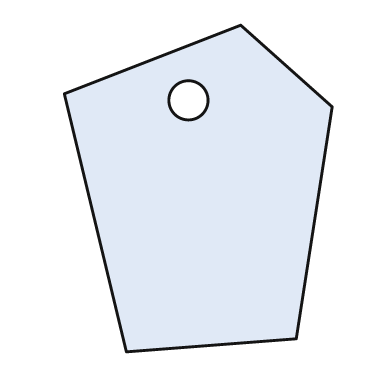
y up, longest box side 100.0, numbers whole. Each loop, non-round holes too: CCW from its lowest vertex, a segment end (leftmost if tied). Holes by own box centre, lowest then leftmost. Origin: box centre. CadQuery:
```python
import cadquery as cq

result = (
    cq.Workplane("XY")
    .moveTo(-22.0, -50.0)
    .lineTo(30.0, -46.0)
    .lineTo(41.0, 25.0)
    .lineTo(13.0, 50.0)
    .lineTo(-41.0, 29.0)
    .close()
    .moveTo(-3.0, 27.0)
    .circle(6.0)
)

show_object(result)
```